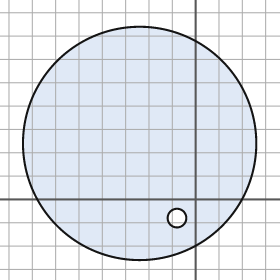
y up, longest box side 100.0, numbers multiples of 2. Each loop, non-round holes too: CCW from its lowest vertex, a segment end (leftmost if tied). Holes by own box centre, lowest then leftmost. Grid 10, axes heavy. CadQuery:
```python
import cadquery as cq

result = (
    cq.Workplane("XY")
    .moveTo(-24.0, 24.0)
    .circle(50.0)
    .moveTo(-8.0, -8.0)
    .circle(4.0)
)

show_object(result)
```